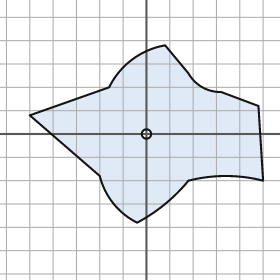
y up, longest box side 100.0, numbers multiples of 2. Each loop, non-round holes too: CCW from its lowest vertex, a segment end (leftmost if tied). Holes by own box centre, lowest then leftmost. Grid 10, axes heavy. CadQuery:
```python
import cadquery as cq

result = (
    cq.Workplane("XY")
    .moveTo(-4.0, -38.0)
    .threePointArc((8.0, -30.0), (18.0, -20.0))
    .threePointArc((34.0, -18.0), (50.0, -20.0))
    .lineTo(48.0, 12.0)
    .lineTo(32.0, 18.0)
    .threePointArc((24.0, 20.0), (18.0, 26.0))
    .lineTo(8.0, 38.0)
    .threePointArc((-6.0, 32.0), (-16.0, 20.0))
    .lineTo(-50.0, 8.0)
    .lineTo(-20.0, -18.0)
    .threePointArc((-14.0, -30.0), (-4.0, -38.0))
    .close()
    .moveTo(0.0, 0.0)
    .circle(2.0)
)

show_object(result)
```